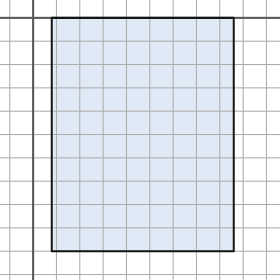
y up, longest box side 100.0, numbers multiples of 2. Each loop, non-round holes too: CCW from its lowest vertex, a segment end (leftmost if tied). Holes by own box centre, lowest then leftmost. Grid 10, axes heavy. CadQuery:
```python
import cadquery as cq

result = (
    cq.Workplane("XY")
    .moveTo(8.0, -100.0)
    .lineTo(86.0, -100.0)
    .lineTo(86.0, 0.0)
    .lineTo(8.0, 0.0)
    .close()
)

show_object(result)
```